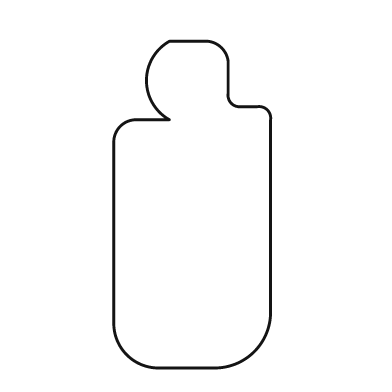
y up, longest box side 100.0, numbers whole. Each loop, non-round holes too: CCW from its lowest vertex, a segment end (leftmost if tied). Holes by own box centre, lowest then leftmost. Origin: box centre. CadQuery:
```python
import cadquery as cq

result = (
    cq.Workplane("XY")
    .moveTo(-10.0, -50.0)
    .lineTo(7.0, -50.0)
    .threePointArc((19.0, -45.0), (24.0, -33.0))
    .lineTo(24.0, 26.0)
    .threePointArc((23.0, 29.0), (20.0, 30.0))
    .lineTo(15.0, 30.0)
    .threePointArc((12.0, 31.0), (11.0, 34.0))
    .lineTo(11.0, 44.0)
    .threePointArc((9.0, 48.0), (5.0, 50.0))
    .lineTo(-7.0, 50.0)
    .threePointArc((-14.0, 38.0), (-7.0, 26.0))
    .lineTo(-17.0, 26.0)
    .threePointArc((-22.0, 24.0), (-24.0, 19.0))
    .lineTo(-24.0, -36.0)
    .threePointArc((-20.0, -46.0), (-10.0, -50.0))
    .close()
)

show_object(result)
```